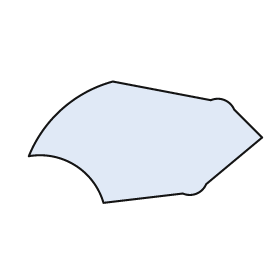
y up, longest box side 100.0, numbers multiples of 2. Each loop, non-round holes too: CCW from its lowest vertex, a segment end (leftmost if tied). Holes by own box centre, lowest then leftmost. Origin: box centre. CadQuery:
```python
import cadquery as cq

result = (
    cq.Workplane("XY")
    .moveTo(-18.0, -26.0)
    .lineTo(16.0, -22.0)
    .threePointArc((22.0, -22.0), (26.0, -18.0))
    .lineTo(50.0, 2.0)
    .lineTo(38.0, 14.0)
    .threePointArc((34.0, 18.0), (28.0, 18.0))
    .lineTo(-14.0, 26.0)
    .threePointArc((-36.0, 14.0), (-50.0, -6.0))
    .threePointArc((-30.0, -10.0), (-18.0, -26.0))
    .close()
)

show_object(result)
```